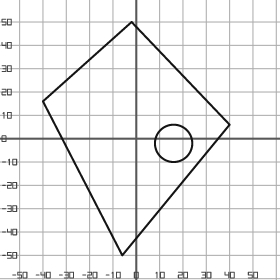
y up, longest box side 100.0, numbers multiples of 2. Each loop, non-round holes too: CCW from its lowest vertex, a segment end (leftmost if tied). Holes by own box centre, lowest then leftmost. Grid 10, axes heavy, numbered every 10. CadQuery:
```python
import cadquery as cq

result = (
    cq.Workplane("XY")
    .moveTo(-6.0, -50.0)
    .lineTo(40.0, 6.0)
    .lineTo(-2.0, 50.0)
    .lineTo(-40.0, 16.0)
    .close()
    .moveTo(16.0, -2.0)
    .circle(8.0)
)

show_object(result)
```